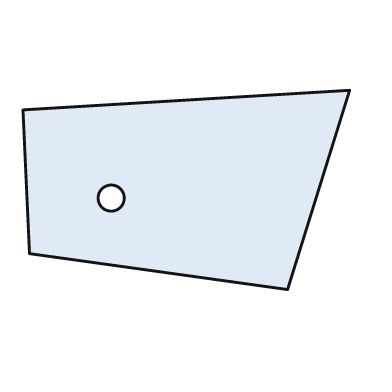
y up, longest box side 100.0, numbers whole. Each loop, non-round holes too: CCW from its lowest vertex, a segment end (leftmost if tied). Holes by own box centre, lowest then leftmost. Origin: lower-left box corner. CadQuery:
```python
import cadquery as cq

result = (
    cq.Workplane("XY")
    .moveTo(81.0, 0.0)
    .lineTo(100.0, 61.0)
    .lineTo(0.0, 55.0)
    .lineTo(2.0, 11.0)
    .close()
    .moveTo(27.0, 28.0)
    .circle(4.0)
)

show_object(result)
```